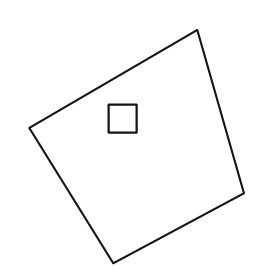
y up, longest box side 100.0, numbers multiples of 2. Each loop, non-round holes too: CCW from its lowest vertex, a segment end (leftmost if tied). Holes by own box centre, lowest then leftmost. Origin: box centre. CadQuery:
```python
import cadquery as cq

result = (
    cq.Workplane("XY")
    .moveTo(-10.0, -50.0)
    .lineTo(46.0, -20.0)
    .lineTo(26.0, 50.0)
    .lineTo(-46.0, 8.0)
    .close()
    .moveTo(-12.0, 6.0)
    .lineTo(0.0, 6.0)
    .lineTo(0.0, 18.0)
    .lineTo(-12.0, 18.0)
    .close()
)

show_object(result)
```